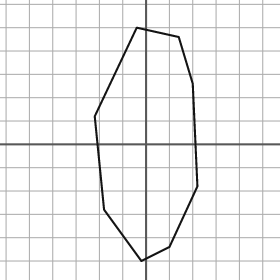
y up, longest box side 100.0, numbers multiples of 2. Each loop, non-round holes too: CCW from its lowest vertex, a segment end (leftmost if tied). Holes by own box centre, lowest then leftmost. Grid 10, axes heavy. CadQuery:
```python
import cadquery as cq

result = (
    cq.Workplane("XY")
    .moveTo(-2.0, -50.0)
    .lineTo(10.0, -44.0)
    .lineTo(22.0, -18.0)
    .lineTo(20.0, 26.0)
    .lineTo(14.0, 46.0)
    .lineTo(-4.0, 50.0)
    .lineTo(-22.0, 12.0)
    .lineTo(-18.0, -28.0)
    .close()
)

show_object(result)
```